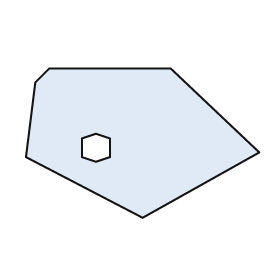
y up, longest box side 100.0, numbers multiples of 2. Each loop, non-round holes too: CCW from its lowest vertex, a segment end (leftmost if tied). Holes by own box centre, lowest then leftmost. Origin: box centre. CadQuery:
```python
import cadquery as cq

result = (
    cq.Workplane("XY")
    .moveTo(0.0, -32.0)
    .lineTo(50.0, -4.0)
    .lineTo(12.0, 32.0)
    .lineTo(-40.0, 32.0)
    .lineTo(-46.0, 26.0)
    .lineTo(-50.0, -6.0)
    .close()
    .moveTo(-20.0, -8.0)
    .lineTo(-14.0, -6.0)
    .lineTo(-14.0, 2.0)
    .lineTo(-20.0, 4.0)
    .lineTo(-26.0, 2.0)
    .lineTo(-26.0, -6.0)
    .close()
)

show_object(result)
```